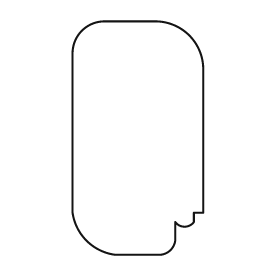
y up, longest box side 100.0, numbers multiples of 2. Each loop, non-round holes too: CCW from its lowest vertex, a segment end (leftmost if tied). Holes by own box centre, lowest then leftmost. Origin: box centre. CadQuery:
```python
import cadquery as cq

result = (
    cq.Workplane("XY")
    .moveTo(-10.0, -50.0)
    .lineTo(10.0, -50.0)
    .threePointArc((14.0, -48.0), (16.0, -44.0))
    .lineTo(16.0, -36.0)
    .threePointArc((20.0, -38.0), (24.0, -36.0))
    .lineTo(24.0, -32.0)
    .lineTo(28.0, -32.0)
    .lineTo(28.0, 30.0)
    .threePointArc((22.0, 44.0), (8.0, 50.0))
    .lineTo(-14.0, 50.0)
    .threePointArc((-24.0, 46.0), (-28.0, 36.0))
    .lineTo(-28.0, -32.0)
    .threePointArc((-22.0, -44.0), (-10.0, -50.0))
    .close()
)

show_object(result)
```